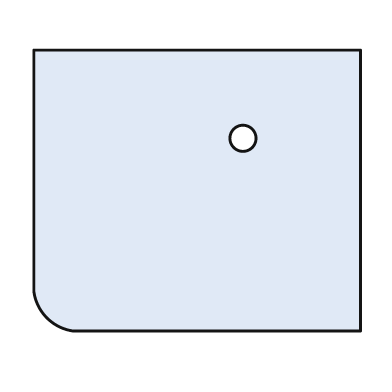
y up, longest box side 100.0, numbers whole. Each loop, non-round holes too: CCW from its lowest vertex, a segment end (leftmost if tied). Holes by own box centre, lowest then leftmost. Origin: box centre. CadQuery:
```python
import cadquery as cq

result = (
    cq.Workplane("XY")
    .moveTo(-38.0, -43.0)
    .lineTo(50.0, -43.0)
    .lineTo(50.0, 43.0)
    .lineTo(-50.0, 43.0)
    .lineTo(-50.0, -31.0)
    .threePointArc((-46.0, -39.0), (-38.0, -43.0))
    .close()
    .moveTo(14.0, 16.0)
    .circle(4.0)
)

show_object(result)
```